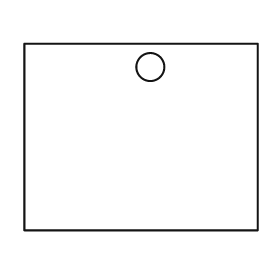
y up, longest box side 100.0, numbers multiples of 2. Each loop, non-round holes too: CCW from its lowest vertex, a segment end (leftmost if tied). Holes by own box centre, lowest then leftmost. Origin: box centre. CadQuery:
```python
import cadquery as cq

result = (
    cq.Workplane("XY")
    .moveTo(-50.0, -40.0)
    .lineTo(50.0, -40.0)
    .lineTo(50.0, 40.0)
    .lineTo(-50.0, 40.0)
    .close()
    .moveTo(4.0, 30.0)
    .circle(6.0)
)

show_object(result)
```